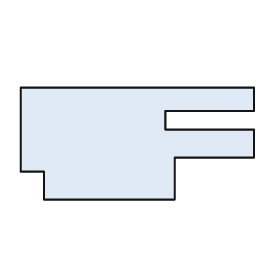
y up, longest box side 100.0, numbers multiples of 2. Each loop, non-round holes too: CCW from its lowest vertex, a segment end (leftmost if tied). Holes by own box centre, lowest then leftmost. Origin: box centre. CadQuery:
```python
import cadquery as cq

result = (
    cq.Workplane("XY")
    .moveTo(-40.0, -24.0)
    .lineTo(16.0, -24.0)
    .lineTo(16.0, -6.0)
    .lineTo(50.0, -6.0)
    .lineTo(50.0, 6.0)
    .lineTo(12.0, 6.0)
    .lineTo(12.0, 14.0)
    .lineTo(50.0, 14.0)
    .lineTo(50.0, 24.0)
    .lineTo(-50.0, 24.0)
    .lineTo(-50.0, -12.0)
    .lineTo(-40.0, -12.0)
    .close()
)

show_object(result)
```